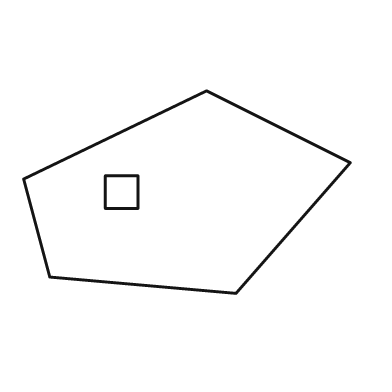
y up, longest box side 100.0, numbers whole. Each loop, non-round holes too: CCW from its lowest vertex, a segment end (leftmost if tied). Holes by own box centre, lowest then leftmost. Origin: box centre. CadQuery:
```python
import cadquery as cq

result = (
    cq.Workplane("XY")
    .moveTo(15.0, -31.0)
    .lineTo(50.0, 9.0)
    .lineTo(6.0, 31.0)
    .lineTo(-50.0, 4.0)
    .lineTo(-42.0, -26.0)
    .close()
    .moveTo(-25.0, -5.0)
    .lineTo(-15.0, -5.0)
    .lineTo(-15.0, 5.0)
    .lineTo(-25.0, 5.0)
    .close()
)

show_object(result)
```